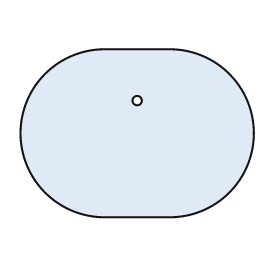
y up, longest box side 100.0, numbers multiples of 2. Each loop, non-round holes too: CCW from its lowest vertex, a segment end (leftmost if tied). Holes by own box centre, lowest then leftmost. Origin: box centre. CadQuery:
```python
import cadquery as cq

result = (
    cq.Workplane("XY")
    .moveTo(-14.0, -36.0)
    .lineTo(14.0, -36.0)
    .threePointArc((50.0, 0.0), (14.0, 36.0))
    .lineTo(-14.0, 36.0)
    .threePointArc((-50.0, 0.0), (-14.0, -36.0))
    .close()
    .moveTo(0.0, 14.0)
    .circle(2.0)
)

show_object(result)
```